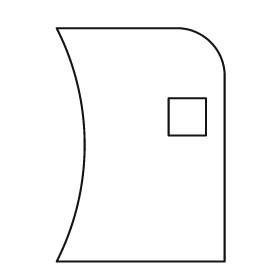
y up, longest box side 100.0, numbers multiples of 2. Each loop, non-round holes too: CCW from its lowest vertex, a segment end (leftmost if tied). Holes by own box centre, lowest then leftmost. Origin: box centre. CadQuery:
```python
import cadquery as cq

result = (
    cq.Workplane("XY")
    .moveTo(-36.0, -50.0)
    .lineTo(36.0, -50.0)
    .lineTo(36.0, 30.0)
    .threePointArc((30.0, 44.0), (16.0, 50.0))
    .lineTo(-36.0, 50.0)
    .threePointArc((-24.0, 0.0), (-36.0, -50.0))
    .close()
    .moveTo(12.0, 4.0)
    .lineTo(28.0, 4.0)
    .lineTo(28.0, 20.0)
    .lineTo(12.0, 20.0)
    .close()
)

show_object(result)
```